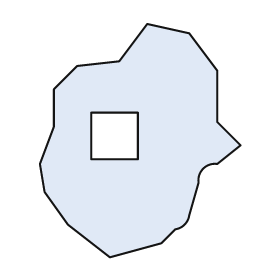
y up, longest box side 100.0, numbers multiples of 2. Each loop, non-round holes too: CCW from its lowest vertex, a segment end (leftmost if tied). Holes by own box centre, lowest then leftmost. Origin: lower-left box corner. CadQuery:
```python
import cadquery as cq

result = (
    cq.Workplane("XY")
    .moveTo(30.0, 0.0)
    .lineTo(52.0, 6.0)
    .lineTo(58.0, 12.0)
    .threePointArc((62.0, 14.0), (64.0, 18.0))
    .lineTo(68.0, 32.0)
    .threePointArc((70.0, 38.0), (76.0, 40.0))
    .lineTo(86.0, 48.0)
    .lineTo(76.0, 58.0)
    .lineTo(76.0, 80.0)
    .lineTo(64.0, 96.0)
    .lineTo(46.0, 100.0)
    .lineTo(34.0, 84.0)
    .lineTo(16.0, 82.0)
    .lineTo(6.0, 72.0)
    .lineTo(6.0, 56.0)
    .lineTo(0.0, 40.0)
    .lineTo(2.0, 28.0)
    .lineTo(12.0, 14.0)
    .close()
    .moveTo(22.0, 42.0)
    .lineTo(42.0, 42.0)
    .lineTo(42.0, 62.0)
    .lineTo(22.0, 62.0)
    .close()
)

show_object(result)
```